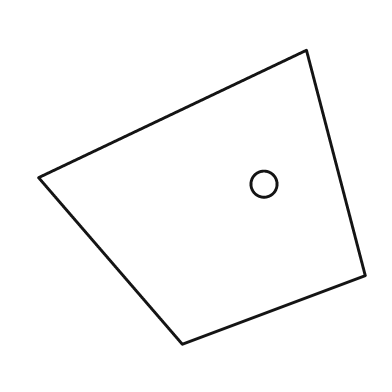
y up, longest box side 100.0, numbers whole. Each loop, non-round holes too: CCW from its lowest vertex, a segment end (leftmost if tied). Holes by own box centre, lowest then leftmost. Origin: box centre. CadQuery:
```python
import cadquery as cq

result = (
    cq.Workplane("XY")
    .moveTo(-6.0, -45.0)
    .lineTo(50.0, -24.0)
    .lineTo(32.0, 45.0)
    .lineTo(-50.0, 6.0)
    .close()
    .moveTo(19.0, 4.0)
    .circle(4.0)
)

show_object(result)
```